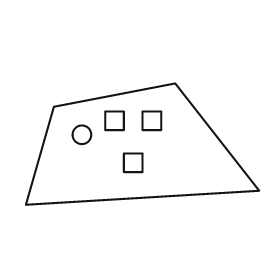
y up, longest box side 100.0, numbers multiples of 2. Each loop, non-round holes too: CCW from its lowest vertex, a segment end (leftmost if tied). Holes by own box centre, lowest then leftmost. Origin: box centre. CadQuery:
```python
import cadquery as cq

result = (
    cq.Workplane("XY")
    .moveTo(-50.0, -26.0)
    .lineTo(50.0, -20.0)
    .lineTo(14.0, 26.0)
    .lineTo(-38.0, 16.0)
    .close()
    .moveTo(-8.0, -12.0)
    .lineTo(0.0, -12.0)
    .lineTo(0.0, -4.0)
    .lineTo(-8.0, -4.0)
    .close()
    .moveTo(-26.0, 4.0)
    .circle(4.0)
    .moveTo(-16.0, 6.0)
    .lineTo(-8.0, 6.0)
    .lineTo(-8.0, 14.0)
    .lineTo(-16.0, 14.0)
    .close()
    .moveTo(0.0, 6.0)
    .lineTo(8.0, 6.0)
    .lineTo(8.0, 14.0)
    .lineTo(0.0, 14.0)
    .close()
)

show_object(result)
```